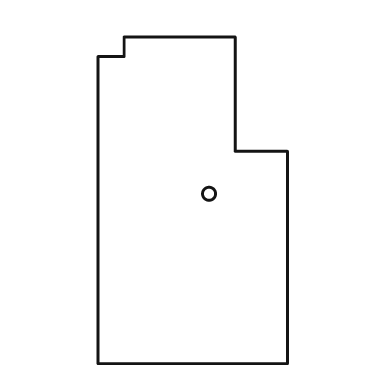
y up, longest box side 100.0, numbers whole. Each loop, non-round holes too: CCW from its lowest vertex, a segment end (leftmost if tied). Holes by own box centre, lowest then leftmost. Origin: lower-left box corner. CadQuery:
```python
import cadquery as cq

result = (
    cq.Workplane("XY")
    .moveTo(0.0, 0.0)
    .lineTo(58.0, 0.0)
    .lineTo(58.0, 65.0)
    .lineTo(42.0, 65.0)
    .lineTo(42.0, 100.0)
    .lineTo(8.0, 100.0)
    .lineTo(8.0, 94.0)
    .lineTo(0.0, 94.0)
    .close()
    .moveTo(34.0, 52.0)
    .circle(2.0)
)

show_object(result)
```